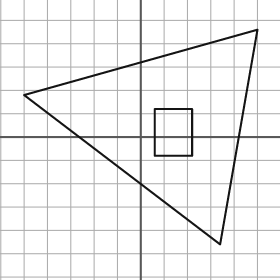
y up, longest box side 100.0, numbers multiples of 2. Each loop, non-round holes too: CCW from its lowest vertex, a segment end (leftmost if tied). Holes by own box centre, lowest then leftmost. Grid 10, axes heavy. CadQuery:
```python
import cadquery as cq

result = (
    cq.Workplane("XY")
    .moveTo(34.0, -46.0)
    .lineTo(50.0, 46.0)
    .lineTo(-50.0, 18.0)
    .close()
    .moveTo(6.0, -8.0)
    .lineTo(22.0, -8.0)
    .lineTo(22.0, 12.0)
    .lineTo(6.0, 12.0)
    .close()
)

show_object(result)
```